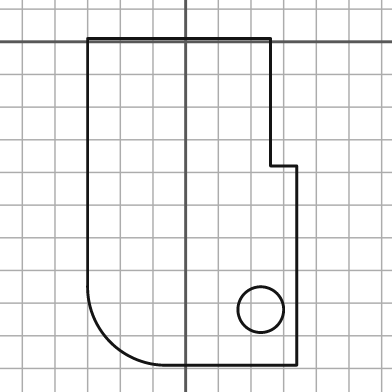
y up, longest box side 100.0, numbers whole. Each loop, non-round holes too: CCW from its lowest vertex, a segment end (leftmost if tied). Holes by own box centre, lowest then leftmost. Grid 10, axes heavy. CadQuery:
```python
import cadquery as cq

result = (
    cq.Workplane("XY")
    .moveTo(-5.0, -99.0)
    .lineTo(34.0, -99.0)
    .lineTo(34.0, -38.0)
    .lineTo(26.0, -38.0)
    .lineTo(26.0, 1.0)
    .lineTo(-30.0, 1.0)
    .lineTo(-30.0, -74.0)
    .threePointArc((-23.0, -92.0), (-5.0, -99.0))
    .close()
    .moveTo(23.0, -82.0)
    .circle(7.0)
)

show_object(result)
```